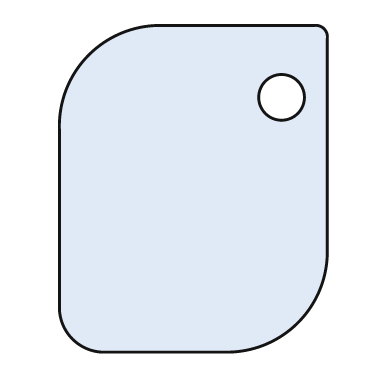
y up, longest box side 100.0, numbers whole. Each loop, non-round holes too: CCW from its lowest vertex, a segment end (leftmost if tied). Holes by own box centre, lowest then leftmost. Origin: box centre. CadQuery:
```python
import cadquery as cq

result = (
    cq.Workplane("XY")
    .moveTo(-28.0, -50.0)
    .lineTo(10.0, -50.0)
    .threePointArc((32.0, -41.0), (41.0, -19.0))
    .lineTo(41.0, 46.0)
    .threePointArc((40.0, 49.0), (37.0, 50.0))
    .lineTo(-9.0, 50.0)
    .threePointArc((-32.0, 41.0), (-41.0, 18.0))
    .lineTo(-41.0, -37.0)
    .threePointArc((-37.0, -46.0), (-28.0, -50.0))
    .close()
    .moveTo(27.0, 28.0)
    .circle(7.0)
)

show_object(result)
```